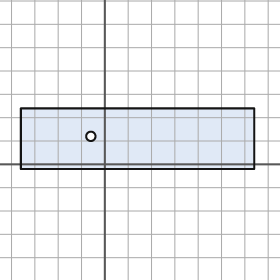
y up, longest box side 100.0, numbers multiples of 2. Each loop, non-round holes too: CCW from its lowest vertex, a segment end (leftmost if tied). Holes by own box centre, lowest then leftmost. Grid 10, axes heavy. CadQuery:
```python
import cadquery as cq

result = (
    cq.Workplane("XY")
    .moveTo(-36.0, -2.0)
    .lineTo(64.0, -2.0)
    .lineTo(64.0, 24.0)
    .lineTo(-36.0, 24.0)
    .close()
    .moveTo(-6.0, 12.0)
    .circle(2.0)
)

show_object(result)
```